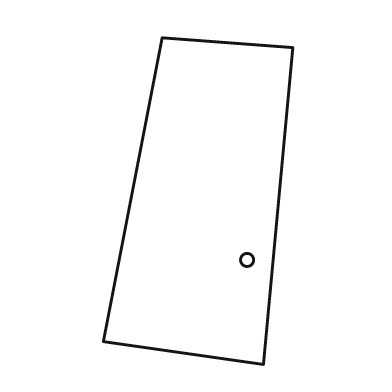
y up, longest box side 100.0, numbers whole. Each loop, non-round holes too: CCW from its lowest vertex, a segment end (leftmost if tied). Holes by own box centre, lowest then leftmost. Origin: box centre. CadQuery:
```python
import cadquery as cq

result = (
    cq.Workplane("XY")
    .moveTo(20.0, -50.0)
    .lineTo(29.0, 47.0)
    .lineTo(-11.0, 50.0)
    .lineTo(-29.0, -43.0)
    .close()
    .moveTo(15.0, -18.0)
    .circle(2.0)
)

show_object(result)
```